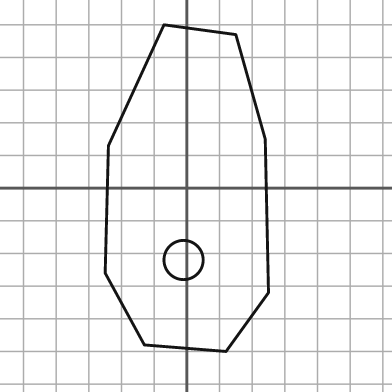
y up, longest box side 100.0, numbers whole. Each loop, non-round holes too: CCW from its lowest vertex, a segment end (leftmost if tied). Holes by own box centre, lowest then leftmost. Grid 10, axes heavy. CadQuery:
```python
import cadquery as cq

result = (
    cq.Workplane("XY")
    .moveTo(12.0, -50.0)
    .lineTo(25.0, -32.0)
    .lineTo(24.0, 15.0)
    .lineTo(15.0, 47.0)
    .lineTo(-7.0, 50.0)
    .lineTo(-24.0, 13.0)
    .lineTo(-25.0, -26.0)
    .lineTo(-13.0, -48.0)
    .close()
    .moveTo(-1.0, -22.0)
    .circle(6.0)
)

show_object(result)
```